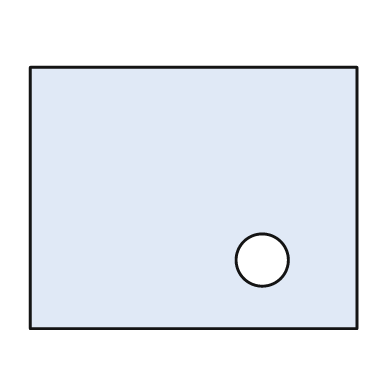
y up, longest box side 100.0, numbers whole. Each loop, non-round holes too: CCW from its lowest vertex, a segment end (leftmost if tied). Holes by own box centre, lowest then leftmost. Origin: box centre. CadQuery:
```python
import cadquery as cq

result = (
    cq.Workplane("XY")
    .moveTo(-50.0, -40.0)
    .lineTo(50.0, -40.0)
    .lineTo(50.0, 40.0)
    .lineTo(-50.0, 40.0)
    .close()
    .moveTo(21.0, -19.0)
    .circle(8.0)
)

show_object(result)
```